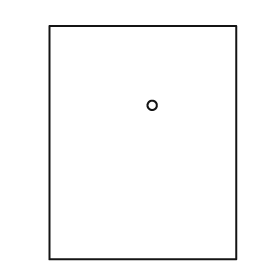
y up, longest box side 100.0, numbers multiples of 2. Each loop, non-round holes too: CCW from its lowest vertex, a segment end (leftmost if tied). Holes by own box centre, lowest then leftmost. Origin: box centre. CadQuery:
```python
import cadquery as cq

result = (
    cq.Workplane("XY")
    .moveTo(-40.0, -50.0)
    .lineTo(40.0, -50.0)
    .lineTo(40.0, 50.0)
    .lineTo(-40.0, 50.0)
    .close()
    .moveTo(4.0, 16.0)
    .circle(2.0)
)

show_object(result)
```